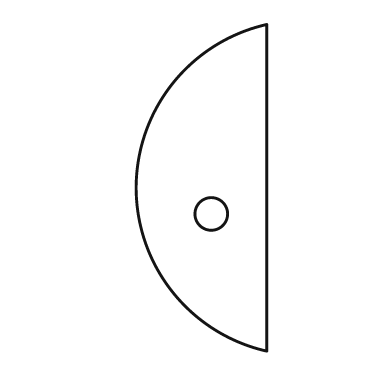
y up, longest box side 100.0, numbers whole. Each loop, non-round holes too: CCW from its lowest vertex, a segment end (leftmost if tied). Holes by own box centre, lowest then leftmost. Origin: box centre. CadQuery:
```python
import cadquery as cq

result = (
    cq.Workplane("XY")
    .moveTo(20.0, -50.0)
    .lineTo(20.0, 50.0)
    .threePointArc((-20.0, 0.0), (20.0, -50.0))
    .close()
    .moveTo(3.0, -8.0)
    .circle(5.0)
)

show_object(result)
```